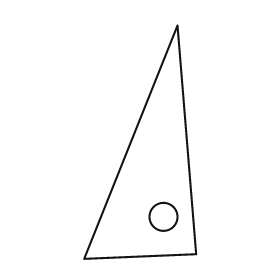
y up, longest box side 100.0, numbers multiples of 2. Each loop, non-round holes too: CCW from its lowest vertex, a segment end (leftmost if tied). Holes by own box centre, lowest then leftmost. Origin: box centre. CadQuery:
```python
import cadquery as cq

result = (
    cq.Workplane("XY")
    .moveTo(-24.0, -50.0)
    .lineTo(24.0, -48.0)
    .lineTo(16.0, 50.0)
    .close()
    .moveTo(10.0, -32.0)
    .circle(6.0)
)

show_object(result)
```